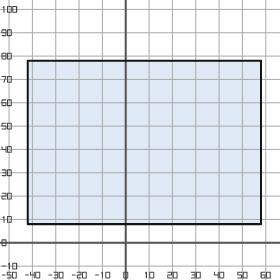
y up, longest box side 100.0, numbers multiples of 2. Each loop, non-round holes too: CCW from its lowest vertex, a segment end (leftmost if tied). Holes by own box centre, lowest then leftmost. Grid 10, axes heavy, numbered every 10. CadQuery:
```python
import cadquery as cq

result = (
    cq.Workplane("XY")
    .moveTo(-42.0, 8.0)
    .lineTo(58.0, 8.0)
    .lineTo(58.0, 78.0)
    .lineTo(-42.0, 78.0)
    .close()
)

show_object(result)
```